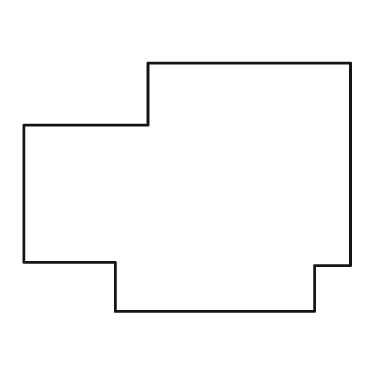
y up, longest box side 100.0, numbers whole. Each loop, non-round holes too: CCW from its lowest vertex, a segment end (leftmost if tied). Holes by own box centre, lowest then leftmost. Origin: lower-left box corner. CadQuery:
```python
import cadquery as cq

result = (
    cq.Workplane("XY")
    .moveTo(28.0, 0.0)
    .lineTo(89.0, 0.0)
    .lineTo(89.0, 14.0)
    .lineTo(100.0, 14.0)
    .lineTo(100.0, 76.0)
    .lineTo(38.0, 76.0)
    .lineTo(38.0, 57.0)
    .lineTo(0.0, 57.0)
    .lineTo(0.0, 15.0)
    .lineTo(28.0, 15.0)
    .close()
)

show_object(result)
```